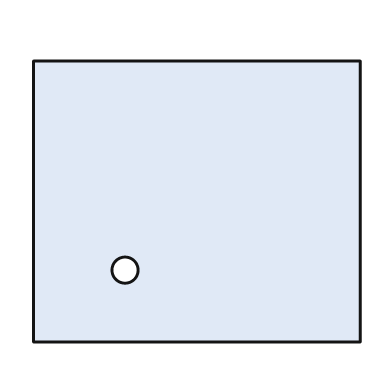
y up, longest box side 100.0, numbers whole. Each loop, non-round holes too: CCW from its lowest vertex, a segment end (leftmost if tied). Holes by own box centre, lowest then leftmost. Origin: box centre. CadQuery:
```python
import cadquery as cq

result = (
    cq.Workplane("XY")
    .moveTo(-50.0, -43.0)
    .lineTo(50.0, -43.0)
    .lineTo(50.0, 43.0)
    .lineTo(-50.0, 43.0)
    .close()
    .moveTo(-22.0, -21.0)
    .circle(4.0)
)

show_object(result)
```